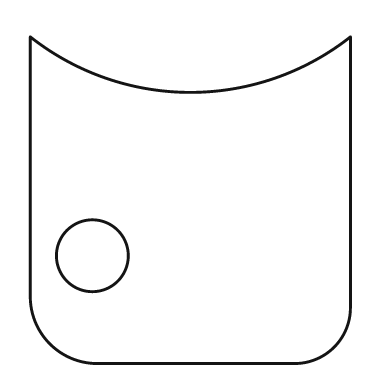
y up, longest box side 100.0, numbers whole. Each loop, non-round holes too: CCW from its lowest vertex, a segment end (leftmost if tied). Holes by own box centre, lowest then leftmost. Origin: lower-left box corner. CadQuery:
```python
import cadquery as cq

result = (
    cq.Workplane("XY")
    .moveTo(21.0, 0.0)
    .lineTo(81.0, 0.0)
    .threePointArc((93.0, 5.0), (98.0, 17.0))
    .lineTo(98.0, 100.0)
    .threePointArc((49.0, 83.0), (0.0, 100.0))
    .lineTo(0.0, 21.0)
    .threePointArc((6.0, 6.0), (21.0, 0.0))
    .close()
    .moveTo(19.0, 33.0)
    .circle(11.0)
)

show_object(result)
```